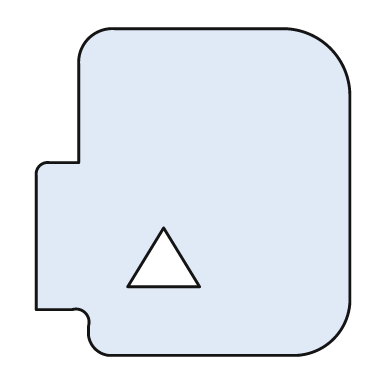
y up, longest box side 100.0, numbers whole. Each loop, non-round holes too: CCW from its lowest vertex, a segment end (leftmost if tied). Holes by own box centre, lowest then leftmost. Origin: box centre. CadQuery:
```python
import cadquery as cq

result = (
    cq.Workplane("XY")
    .moveTo(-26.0, -50.0)
    .lineTo(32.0, -50.0)
    .threePointArc((43.0, -45.0), (48.0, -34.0))
    .lineTo(48.0, 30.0)
    .threePointArc((42.0, 44.0), (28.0, 50.0))
    .lineTo(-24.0, 50.0)
    .threePointArc((-32.0, 47.0), (-35.0, 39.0))
    .lineTo(-35.0, 9.0)
    .lineTo(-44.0, 9.0)
    .threePointArc((-47.0, 8.0), (-48.0, 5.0))
    .lineTo(-48.0, -36.0)
    .lineTo(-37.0, -36.0)
    .threePointArc((-33.0, -37.0), (-32.0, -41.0))
    .lineTo(-32.0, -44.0)
    .threePointArc((-30.0, -48.0), (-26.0, -50.0))
    .close()
    .moveTo(-20.0, -29.0)
    .lineTo(2.0, -29.0)
    .lineTo(-9.0, -11.0)
    .close()
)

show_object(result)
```